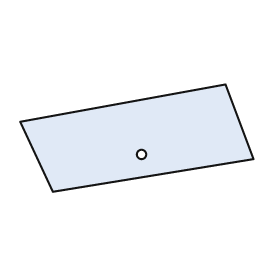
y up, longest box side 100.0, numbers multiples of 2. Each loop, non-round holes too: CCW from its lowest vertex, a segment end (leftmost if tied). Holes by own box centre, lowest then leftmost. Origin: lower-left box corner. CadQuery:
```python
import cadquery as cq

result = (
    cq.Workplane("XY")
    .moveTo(14.0, 0.0)
    .lineTo(100.0, 14.0)
    .lineTo(88.0, 46.0)
    .lineTo(0.0, 30.0)
    .close()
    .moveTo(52.0, 16.0)
    .circle(2.0)
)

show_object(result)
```